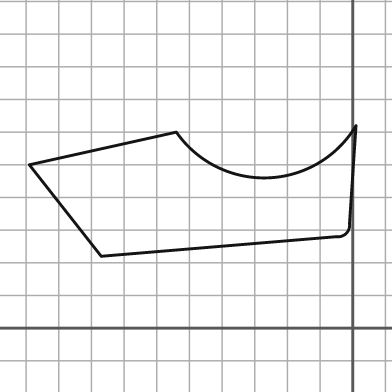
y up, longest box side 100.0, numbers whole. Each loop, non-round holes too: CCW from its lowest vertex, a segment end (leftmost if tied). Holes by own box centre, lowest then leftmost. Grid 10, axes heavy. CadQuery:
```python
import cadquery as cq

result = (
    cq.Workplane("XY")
    .moveTo(-77.0, 22.0)
    .lineTo(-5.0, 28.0)
    .threePointArc((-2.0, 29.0), (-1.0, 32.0))
    .lineTo(1.0, 62.0)
    .threePointArc((-26.0, 46.0), (-54.0, 60.0))
    .lineTo(-99.0, 50.0)
    .close()
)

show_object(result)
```